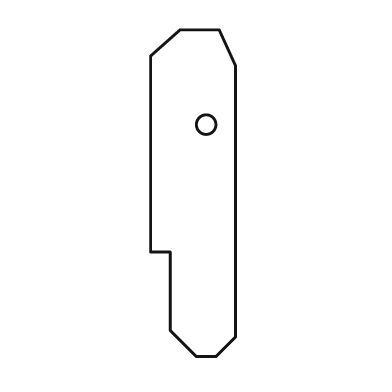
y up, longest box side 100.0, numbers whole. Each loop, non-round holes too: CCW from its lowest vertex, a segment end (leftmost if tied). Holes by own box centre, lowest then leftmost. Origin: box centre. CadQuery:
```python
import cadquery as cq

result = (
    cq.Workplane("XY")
    .moveTo(1.0, -50.0)
    .lineTo(7.0, -50.0)
    .lineTo(13.0, -44.0)
    .lineTo(13.0, 39.0)
    .lineTo(8.0, 50.0)
    .lineTo(-4.0, 50.0)
    .lineTo(-13.0, 42.0)
    .lineTo(-13.0, -18.0)
    .lineTo(-7.0, -18.0)
    .lineTo(-7.0, -42.0)
    .close()
    .moveTo(4.0, 21.0)
    .circle(3.0)
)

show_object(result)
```